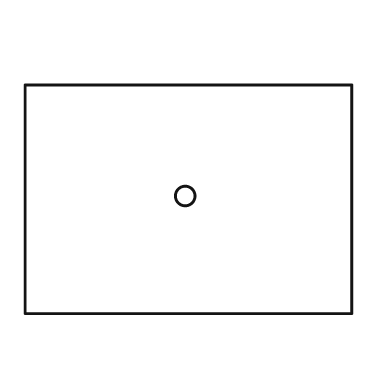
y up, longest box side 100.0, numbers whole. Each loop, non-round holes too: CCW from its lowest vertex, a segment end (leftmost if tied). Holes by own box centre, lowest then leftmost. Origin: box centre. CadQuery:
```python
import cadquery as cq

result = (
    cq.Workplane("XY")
    .moveTo(-50.0, -35.0)
    .lineTo(50.0, -35.0)
    .lineTo(50.0, 35.0)
    .lineTo(-50.0, 35.0)
    .close()
    .moveTo(-1.0, 1.0)
    .circle(3.0)
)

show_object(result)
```